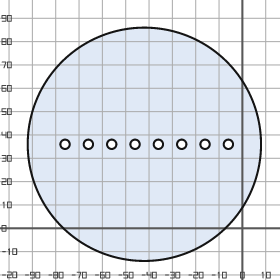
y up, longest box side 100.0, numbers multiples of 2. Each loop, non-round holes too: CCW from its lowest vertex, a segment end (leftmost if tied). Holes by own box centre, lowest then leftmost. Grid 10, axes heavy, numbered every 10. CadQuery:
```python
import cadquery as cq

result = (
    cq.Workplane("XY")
    .moveTo(-42.0, 36.0)
    .circle(50.0)
    .moveTo(-76.0, 36.0)
    .circle(2.0)
    .moveTo(-66.0, 36.0)
    .circle(2.0)
    .moveTo(-56.0, 36.0)
    .circle(2.0)
    .moveTo(-46.0, 36.0)
    .circle(2.0)
    .moveTo(-36.0, 36.0)
    .circle(2.0)
    .moveTo(-26.0, 36.0)
    .circle(2.0)
    .moveTo(-16.0, 36.0)
    .circle(2.0)
    .moveTo(-6.0, 36.0)
    .circle(2.0)
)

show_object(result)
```